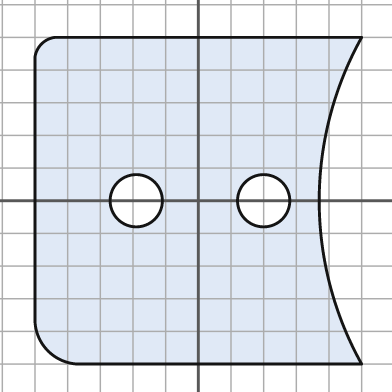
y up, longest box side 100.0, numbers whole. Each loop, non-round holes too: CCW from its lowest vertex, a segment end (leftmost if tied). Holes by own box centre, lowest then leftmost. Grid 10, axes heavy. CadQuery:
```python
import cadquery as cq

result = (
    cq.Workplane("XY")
    .moveTo(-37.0, -50.0)
    .lineTo(50.0, -50.0)
    .threePointArc((37.0, 0.0), (50.0, 50.0))
    .lineTo(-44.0, 50.0)
    .threePointArc((-48.0, 48.0), (-50.0, 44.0))
    .lineTo(-50.0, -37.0)
    .threePointArc((-46.0, -46.0), (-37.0, -50.0))
    .close()
    .moveTo(-19.0, 0.0)
    .circle(8.0)
    .moveTo(20.0, 0.0)
    .circle(8.0)
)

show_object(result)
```